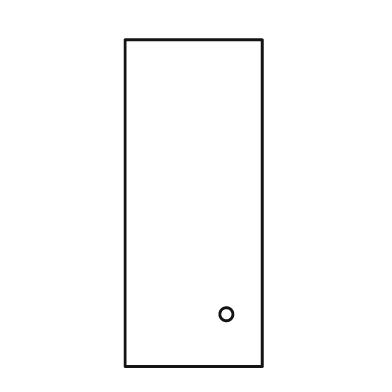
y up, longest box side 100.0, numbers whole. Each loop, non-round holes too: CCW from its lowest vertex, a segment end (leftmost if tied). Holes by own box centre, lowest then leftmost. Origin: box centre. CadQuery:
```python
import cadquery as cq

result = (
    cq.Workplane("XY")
    .moveTo(-21.0, -50.0)
    .lineTo(21.0, -50.0)
    .lineTo(21.0, 50.0)
    .lineTo(-21.0, 50.0)
    .close()
    .moveTo(10.0, -34.0)
    .circle(2.0)
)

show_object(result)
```